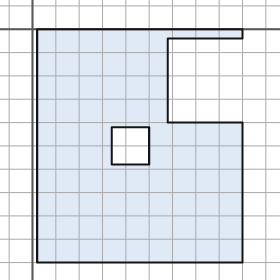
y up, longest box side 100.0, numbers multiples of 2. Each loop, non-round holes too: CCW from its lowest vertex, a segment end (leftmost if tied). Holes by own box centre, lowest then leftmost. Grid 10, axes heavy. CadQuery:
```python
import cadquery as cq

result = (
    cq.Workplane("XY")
    .moveTo(2.0, -100.0)
    .lineTo(90.0, -100.0)
    .lineTo(90.0, -40.0)
    .lineTo(58.0, -40.0)
    .lineTo(58.0, -4.0)
    .lineTo(90.0, -4.0)
    .lineTo(90.0, 0.0)
    .lineTo(2.0, 0.0)
    .close()
    .moveTo(34.0, -58.0)
    .lineTo(50.0, -58.0)
    .lineTo(50.0, -42.0)
    .lineTo(34.0, -42.0)
    .close()
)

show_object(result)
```